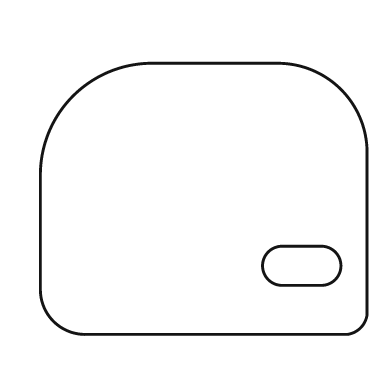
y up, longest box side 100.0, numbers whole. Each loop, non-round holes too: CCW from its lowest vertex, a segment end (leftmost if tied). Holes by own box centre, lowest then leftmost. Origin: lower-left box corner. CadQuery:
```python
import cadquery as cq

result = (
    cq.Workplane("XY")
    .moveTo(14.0, 0.0)
    .lineTo(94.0, 0.0)
    .threePointArc((98.0, 2.0), (100.0, 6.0))
    .lineTo(100.0, 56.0)
    .threePointArc((92.0, 75.0), (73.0, 83.0))
    .lineTo(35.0, 83.0)
    .threePointArc((10.0, 73.0), (0.0, 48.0))
    .lineTo(0.0, 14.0)
    .threePointArc((4.0, 4.0), (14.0, 0.0))
    .close()
    .moveTo(74.0, 15.0)
    .lineTo(86.0, 15.0)
    .threePointArc((92.0, 21.0), (86.0, 27.0))
    .lineTo(74.0, 27.0)
    .threePointArc((68.0, 21.0), (74.0, 15.0))
    .close()
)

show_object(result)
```